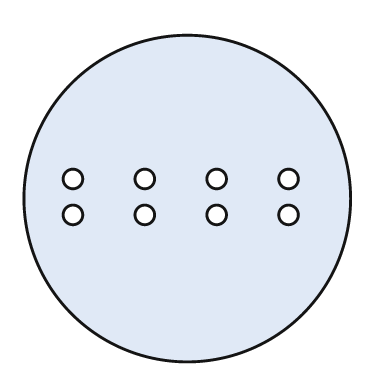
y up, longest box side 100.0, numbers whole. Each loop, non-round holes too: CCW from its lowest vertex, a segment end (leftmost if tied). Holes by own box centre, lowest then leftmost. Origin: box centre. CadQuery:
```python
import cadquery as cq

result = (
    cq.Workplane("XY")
    .moveTo(0.0, 0.0)
    .circle(50.0)
    .moveTo(-35.0, -5.0)
    .circle(3.0)
    .moveTo(-13.0, -5.0)
    .circle(3.0)
    .moveTo(9.0, -5.0)
    .circle(3.0)
    .moveTo(31.0, -5.0)
    .circle(3.0)
    .moveTo(-35.0, 6.0)
    .circle(3.0)
    .moveTo(-13.0, 6.0)
    .circle(3.0)
    .moveTo(9.0, 6.0)
    .circle(3.0)
    .moveTo(31.0, 6.0)
    .circle(3.0)
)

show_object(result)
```